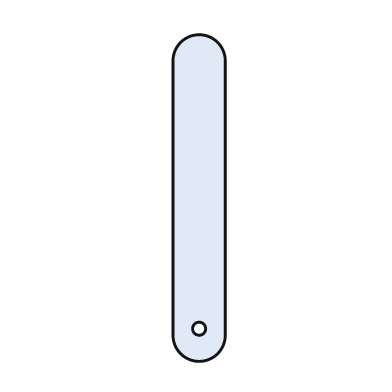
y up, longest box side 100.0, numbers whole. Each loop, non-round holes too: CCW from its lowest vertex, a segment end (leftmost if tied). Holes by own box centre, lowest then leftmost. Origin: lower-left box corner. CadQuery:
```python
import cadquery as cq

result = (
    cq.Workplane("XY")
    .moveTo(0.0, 8.0)
    .threePointArc((8.0, 0.0), (16.0, 8.0))
    .lineTo(16.0, 92.0)
    .threePointArc((8.0, 100.0), (0.0, 92.0))
    .close()
    .moveTo(8.0, 10.0)
    .circle(2.0)
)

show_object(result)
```